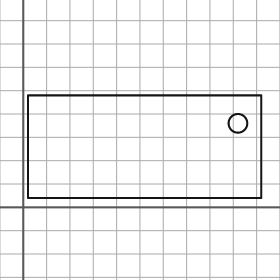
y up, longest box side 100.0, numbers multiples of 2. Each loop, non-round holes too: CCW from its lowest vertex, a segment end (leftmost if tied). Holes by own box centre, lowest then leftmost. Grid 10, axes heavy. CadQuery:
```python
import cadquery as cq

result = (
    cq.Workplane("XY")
    .moveTo(2.0, 4.0)
    .lineTo(102.0, 4.0)
    .lineTo(102.0, 48.0)
    .lineTo(2.0, 48.0)
    .close()
    .moveTo(92.0, 36.0)
    .circle(4.0)
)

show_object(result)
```